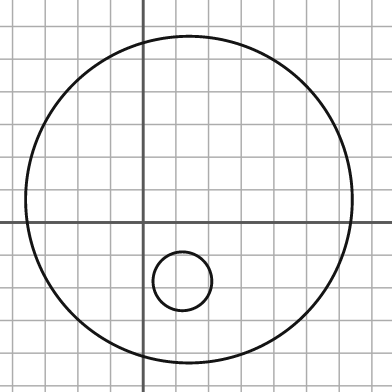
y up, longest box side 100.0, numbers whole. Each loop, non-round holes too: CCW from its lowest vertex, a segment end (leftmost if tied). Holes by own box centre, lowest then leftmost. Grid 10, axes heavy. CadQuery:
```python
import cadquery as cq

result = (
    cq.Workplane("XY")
    .moveTo(14.0, 7.0)
    .circle(50.0)
    .moveTo(12.0, -18.0)
    .circle(9.0)
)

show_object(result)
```